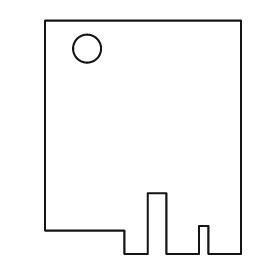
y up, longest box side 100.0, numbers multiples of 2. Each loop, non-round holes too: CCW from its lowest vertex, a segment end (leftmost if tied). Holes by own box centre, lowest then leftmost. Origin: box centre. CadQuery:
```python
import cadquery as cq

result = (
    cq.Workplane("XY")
    .moveTo(-8.0, -50.0)
    .lineTo(2.0, -50.0)
    .lineTo(2.0, -24.0)
    .lineTo(10.0, -24.0)
    .lineTo(10.0, -50.0)
    .lineTo(24.0, -50.0)
    .lineTo(24.0, -38.0)
    .lineTo(28.0, -38.0)
    .lineTo(28.0, -50.0)
    .lineTo(42.0, -50.0)
    .lineTo(42.0, 50.0)
    .lineTo(-42.0, 50.0)
    .lineTo(-42.0, -40.0)
    .lineTo(-8.0, -40.0)
    .close()
    .moveTo(-24.0, 38.0)
    .circle(6.0)
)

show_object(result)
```